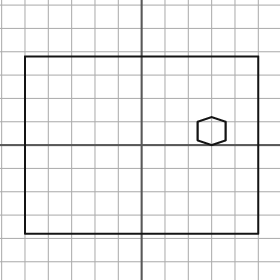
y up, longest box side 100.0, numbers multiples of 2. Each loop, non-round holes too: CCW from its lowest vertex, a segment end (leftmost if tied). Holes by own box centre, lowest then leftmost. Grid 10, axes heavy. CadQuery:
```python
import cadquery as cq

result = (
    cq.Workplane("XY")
    .moveTo(-50.0, -38.0)
    .lineTo(50.0, -38.0)
    .lineTo(50.0, 38.0)
    .lineTo(-50.0, 38.0)
    .close()
    .moveTo(30.0, 0.0)
    .lineTo(36.0, 2.0)
    .lineTo(36.0, 10.0)
    .lineTo(30.0, 12.0)
    .lineTo(24.0, 10.0)
    .lineTo(24.0, 2.0)
    .close()
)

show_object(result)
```